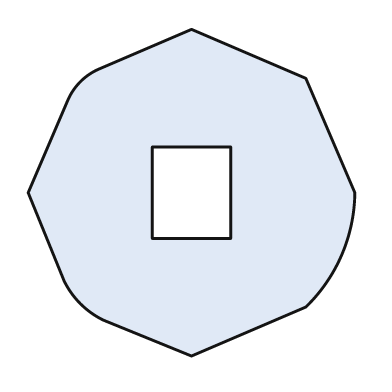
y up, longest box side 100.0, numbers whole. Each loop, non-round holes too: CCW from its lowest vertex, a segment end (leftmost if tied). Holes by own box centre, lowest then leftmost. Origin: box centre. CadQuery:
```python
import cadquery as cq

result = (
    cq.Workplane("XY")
    .moveTo(0.0, -50.0)
    .lineTo(35.0, -35.0)
    .threePointArc((46.0, -19.0), (50.0, 0.0))
    .lineTo(35.0, 35.0)
    .lineTo(0.0, 50.0)
    .lineTo(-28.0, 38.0)
    .threePointArc((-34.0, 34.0), (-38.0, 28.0))
    .lineTo(-50.0, 0.0)
    .lineTo(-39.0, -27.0)
    .threePointArc((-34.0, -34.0), (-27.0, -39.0))
    .close()
    .moveTo(-12.0, -14.0)
    .lineTo(12.0, -14.0)
    .lineTo(12.0, 14.0)
    .lineTo(-12.0, 14.0)
    .close()
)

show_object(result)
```